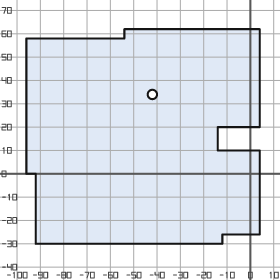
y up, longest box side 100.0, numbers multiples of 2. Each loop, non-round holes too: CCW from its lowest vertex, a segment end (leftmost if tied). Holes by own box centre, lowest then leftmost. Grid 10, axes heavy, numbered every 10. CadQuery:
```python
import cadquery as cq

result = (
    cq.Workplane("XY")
    .moveTo(-92.0, -30.0)
    .lineTo(-12.0, -30.0)
    .lineTo(-12.0, -26.0)
    .lineTo(4.0, -26.0)
    .lineTo(4.0, 10.0)
    .lineTo(-14.0, 10.0)
    .lineTo(-14.0, 20.0)
    .lineTo(4.0, 20.0)
    .lineTo(4.0, 62.0)
    .lineTo(-54.0, 62.0)
    .lineTo(-54.0, 58.0)
    .lineTo(-96.0, 58.0)
    .lineTo(-96.0, 0.0)
    .lineTo(-92.0, 0.0)
    .close()
    .moveTo(-42.0, 34.0)
    .circle(2.0)
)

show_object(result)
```